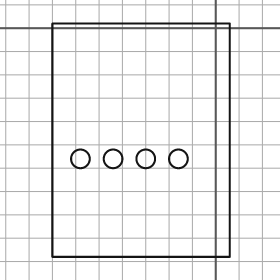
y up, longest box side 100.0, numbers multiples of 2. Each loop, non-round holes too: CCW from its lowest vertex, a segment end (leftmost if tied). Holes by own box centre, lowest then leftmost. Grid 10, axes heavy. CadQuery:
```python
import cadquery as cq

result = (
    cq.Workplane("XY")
    .moveTo(-70.0, -98.0)
    .lineTo(6.0, -98.0)
    .lineTo(6.0, 2.0)
    .lineTo(-70.0, 2.0)
    .close()
    .moveTo(-58.0, -56.0)
    .circle(4.0)
    .moveTo(-44.0, -56.0)
    .circle(4.0)
    .moveTo(-30.0, -56.0)
    .circle(4.0)
    .moveTo(-16.0, -56.0)
    .circle(4.0)
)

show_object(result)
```